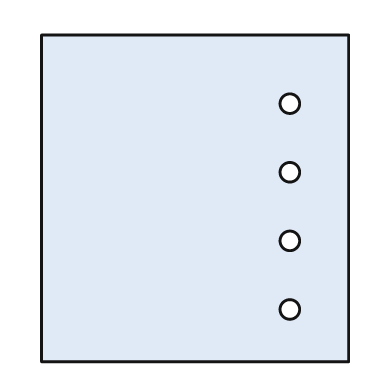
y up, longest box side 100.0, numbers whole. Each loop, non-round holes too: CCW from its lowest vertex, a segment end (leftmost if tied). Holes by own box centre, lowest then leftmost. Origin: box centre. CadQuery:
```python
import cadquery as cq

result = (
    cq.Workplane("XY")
    .moveTo(-47.0, -50.0)
    .lineTo(47.0, -50.0)
    .lineTo(47.0, 50.0)
    .lineTo(-47.0, 50.0)
    .close()
    .moveTo(29.0, -34.0)
    .circle(3.0)
    .moveTo(29.0, -13.0)
    .circle(3.0)
    .moveTo(29.0, 8.0)
    .circle(3.0)
    .moveTo(29.0, 29.0)
    .circle(3.0)
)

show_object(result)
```